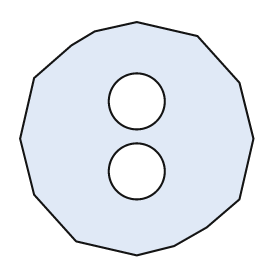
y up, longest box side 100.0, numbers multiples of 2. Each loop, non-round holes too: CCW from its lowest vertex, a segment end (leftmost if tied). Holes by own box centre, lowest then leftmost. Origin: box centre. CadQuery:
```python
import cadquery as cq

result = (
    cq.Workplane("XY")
    .moveTo(0.0, -50.0)
    .lineTo(16.0, -46.0)
    .lineTo(30.0, -38.0)
    .lineTo(44.0, -26.0)
    .lineTo(50.0, 0.0)
    .lineTo(44.0, 24.0)
    .lineTo(26.0, 44.0)
    .lineTo(0.0, 50.0)
    .lineTo(-18.0, 46.0)
    .lineTo(-28.0, 40.0)
    .lineTo(-44.0, 26.0)
    .lineTo(-50.0, 0.0)
    .lineTo(-44.0, -24.0)
    .lineTo(-26.0, -44.0)
    .close()
    .moveTo(0.0, -14.0)
    .circle(12.0)
    .moveTo(0.0, 16.0)
    .circle(12.0)
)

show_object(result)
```